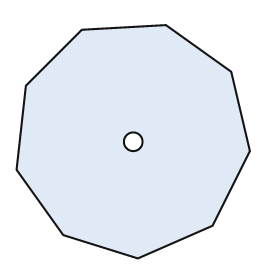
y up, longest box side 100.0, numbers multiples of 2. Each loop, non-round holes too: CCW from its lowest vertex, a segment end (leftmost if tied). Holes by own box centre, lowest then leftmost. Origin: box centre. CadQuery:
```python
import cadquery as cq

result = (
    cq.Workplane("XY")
    .moveTo(2.0, -50.0)
    .lineTo(34.0, -36.0)
    .lineTo(50.0, -4.0)
    .lineTo(42.0, 30.0)
    .lineTo(14.0, 50.0)
    .lineTo(-22.0, 48.0)
    .lineTo(-46.0, 24.0)
    .lineTo(-50.0, -12.0)
    .lineTo(-30.0, -40.0)
    .close()
    .moveTo(0.0, 0.0)
    .circle(4.0)
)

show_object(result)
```